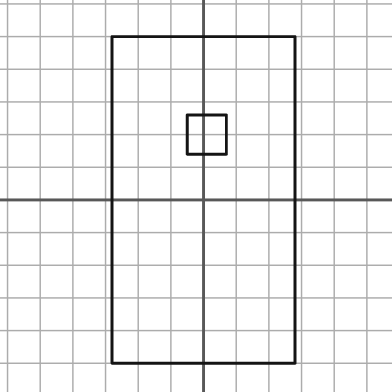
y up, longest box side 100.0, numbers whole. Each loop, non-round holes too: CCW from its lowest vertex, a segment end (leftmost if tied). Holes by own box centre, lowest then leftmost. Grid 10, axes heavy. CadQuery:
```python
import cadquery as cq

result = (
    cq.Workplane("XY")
    .moveTo(-28.0, -50.0)
    .lineTo(28.0, -50.0)
    .lineTo(28.0, 50.0)
    .lineTo(-28.0, 50.0)
    .close()
    .moveTo(-5.0, 14.0)
    .lineTo(7.0, 14.0)
    .lineTo(7.0, 26.0)
    .lineTo(-5.0, 26.0)
    .close()
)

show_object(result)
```